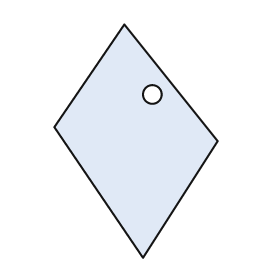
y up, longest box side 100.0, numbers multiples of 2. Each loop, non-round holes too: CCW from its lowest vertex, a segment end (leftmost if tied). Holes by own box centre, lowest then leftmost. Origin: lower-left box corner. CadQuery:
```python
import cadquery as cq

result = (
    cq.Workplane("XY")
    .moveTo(38.0, 0.0)
    .lineTo(70.0, 50.0)
    .lineTo(30.0, 100.0)
    .lineTo(0.0, 56.0)
    .close()
    .moveTo(42.0, 70.0)
    .circle(4.0)
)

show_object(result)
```